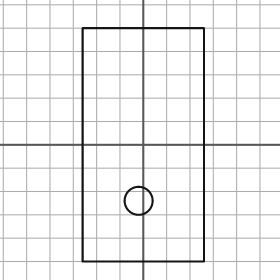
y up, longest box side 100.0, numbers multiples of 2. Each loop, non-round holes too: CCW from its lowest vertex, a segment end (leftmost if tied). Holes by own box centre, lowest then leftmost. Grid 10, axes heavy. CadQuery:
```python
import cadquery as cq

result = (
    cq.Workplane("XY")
    .moveTo(-26.0, -50.0)
    .lineTo(26.0, -50.0)
    .lineTo(26.0, 50.0)
    .lineTo(-26.0, 50.0)
    .close()
    .moveTo(-2.0, -24.0)
    .circle(6.0)
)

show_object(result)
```